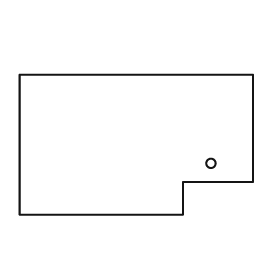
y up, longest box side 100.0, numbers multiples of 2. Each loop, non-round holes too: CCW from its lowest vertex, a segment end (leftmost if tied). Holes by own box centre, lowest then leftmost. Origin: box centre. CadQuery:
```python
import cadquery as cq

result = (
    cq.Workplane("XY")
    .moveTo(-50.0, -30.0)
    .lineTo(20.0, -30.0)
    .lineTo(20.0, -16.0)
    .lineTo(50.0, -16.0)
    .lineTo(50.0, 30.0)
    .lineTo(-50.0, 30.0)
    .close()
    .moveTo(32.0, -8.0)
    .circle(2.0)
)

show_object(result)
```